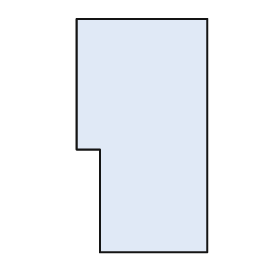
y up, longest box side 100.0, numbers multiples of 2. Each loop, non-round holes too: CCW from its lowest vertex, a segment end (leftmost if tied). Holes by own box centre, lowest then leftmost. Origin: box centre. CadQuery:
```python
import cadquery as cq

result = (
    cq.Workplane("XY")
    .moveTo(-18.0, -50.0)
    .lineTo(28.0, -50.0)
    .lineTo(28.0, 50.0)
    .lineTo(-28.0, 50.0)
    .lineTo(-28.0, -6.0)
    .lineTo(-18.0, -6.0)
    .close()
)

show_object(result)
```